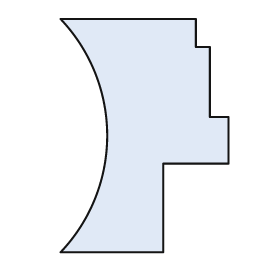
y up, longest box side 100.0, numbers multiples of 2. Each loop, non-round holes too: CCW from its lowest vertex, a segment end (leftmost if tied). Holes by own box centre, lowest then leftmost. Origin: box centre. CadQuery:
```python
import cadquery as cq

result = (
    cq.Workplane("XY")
    .moveTo(-36.0, -50.0)
    .lineTo(8.0, -50.0)
    .lineTo(8.0, -12.0)
    .lineTo(36.0, -12.0)
    .lineTo(36.0, 8.0)
    .lineTo(28.0, 8.0)
    .lineTo(28.0, 38.0)
    .lineTo(22.0, 38.0)
    .lineTo(22.0, 50.0)
    .lineTo(-36.0, 50.0)
    .threePointArc((-16.0, 0.0), (-36.0, -50.0))
    .close()
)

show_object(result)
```